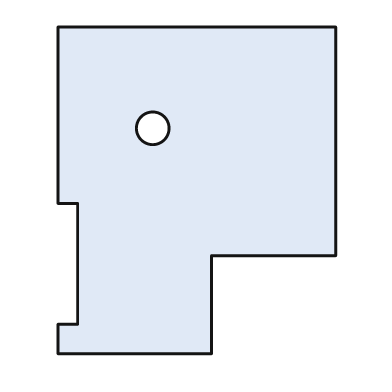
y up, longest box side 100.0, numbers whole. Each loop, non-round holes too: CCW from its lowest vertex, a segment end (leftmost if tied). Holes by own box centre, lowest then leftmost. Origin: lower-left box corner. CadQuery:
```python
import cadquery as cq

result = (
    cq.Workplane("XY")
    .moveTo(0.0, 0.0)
    .lineTo(47.0, 0.0)
    .lineTo(47.0, 30.0)
    .lineTo(85.0, 30.0)
    .lineTo(85.0, 100.0)
    .lineTo(0.0, 100.0)
    .lineTo(0.0, 46.0)
    .lineTo(6.0, 46.0)
    .lineTo(6.0, 9.0)
    .lineTo(0.0, 9.0)
    .close()
    .moveTo(29.0, 69.0)
    .circle(5.0)
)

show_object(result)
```